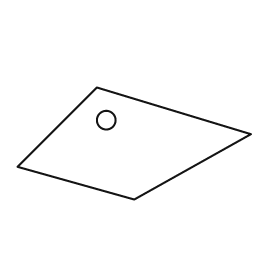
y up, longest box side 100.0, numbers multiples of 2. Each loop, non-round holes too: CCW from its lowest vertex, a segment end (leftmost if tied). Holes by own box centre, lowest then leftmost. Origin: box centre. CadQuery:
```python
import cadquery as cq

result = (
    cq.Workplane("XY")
    .moveTo(0.0, -24.0)
    .lineTo(50.0, 4.0)
    .lineTo(-16.0, 24.0)
    .lineTo(-50.0, -10.0)
    .close()
    .moveTo(-12.0, 10.0)
    .circle(4.0)
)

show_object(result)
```